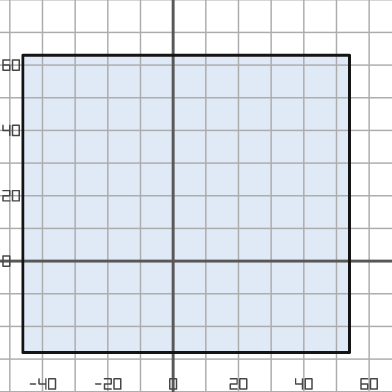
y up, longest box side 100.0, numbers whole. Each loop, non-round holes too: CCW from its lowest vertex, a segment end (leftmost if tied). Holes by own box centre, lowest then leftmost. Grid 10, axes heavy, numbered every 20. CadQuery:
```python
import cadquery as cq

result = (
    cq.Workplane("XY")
    .moveTo(-46.0, -28.0)
    .lineTo(54.0, -28.0)
    .lineTo(54.0, 63.0)
    .lineTo(-46.0, 63.0)
    .close()
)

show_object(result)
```